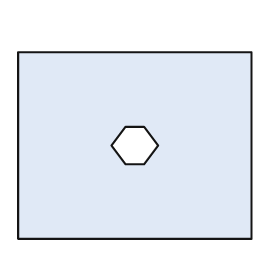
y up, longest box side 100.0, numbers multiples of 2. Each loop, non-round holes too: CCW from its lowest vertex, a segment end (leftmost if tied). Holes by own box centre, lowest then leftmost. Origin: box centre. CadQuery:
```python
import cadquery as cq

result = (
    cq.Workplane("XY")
    .moveTo(-50.0, -40.0)
    .lineTo(50.0, -40.0)
    .lineTo(50.0, 40.0)
    .lineTo(-50.0, 40.0)
    .close()
    .moveTo(-4.0, -8.0)
    .lineTo(4.0, -8.0)
    .lineTo(10.0, 0.0)
    .lineTo(4.0, 8.0)
    .lineTo(-4.0, 8.0)
    .lineTo(-10.0, 0.0)
    .close()
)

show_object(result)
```